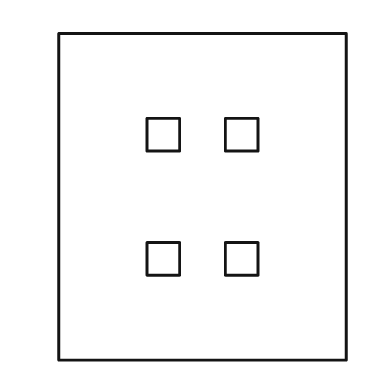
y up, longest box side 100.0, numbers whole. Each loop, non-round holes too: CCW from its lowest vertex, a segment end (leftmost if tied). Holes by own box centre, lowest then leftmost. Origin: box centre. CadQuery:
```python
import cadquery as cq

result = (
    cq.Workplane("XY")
    .moveTo(-44.0, -50.0)
    .lineTo(44.0, -50.0)
    .lineTo(44.0, 50.0)
    .lineTo(-44.0, 50.0)
    .close()
    .moveTo(-17.0, -24.0)
    .lineTo(-7.0, -24.0)
    .lineTo(-7.0, -14.0)
    .lineTo(-17.0, -14.0)
    .close()
    .moveTo(7.0, -24.0)
    .lineTo(17.0, -24.0)
    .lineTo(17.0, -14.0)
    .lineTo(7.0, -14.0)
    .close()
    .moveTo(-17.0, 14.0)
    .lineTo(-7.0, 14.0)
    .lineTo(-7.0, 24.0)
    .lineTo(-17.0, 24.0)
    .close()
    .moveTo(7.0, 14.0)
    .lineTo(17.0, 14.0)
    .lineTo(17.0, 24.0)
    .lineTo(7.0, 24.0)
    .close()
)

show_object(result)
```